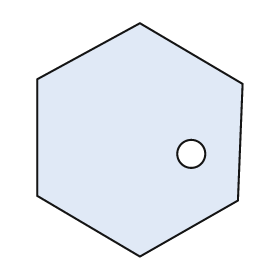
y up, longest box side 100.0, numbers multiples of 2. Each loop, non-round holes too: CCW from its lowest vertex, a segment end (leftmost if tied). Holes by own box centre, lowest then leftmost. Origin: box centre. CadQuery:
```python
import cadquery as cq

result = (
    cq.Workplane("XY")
    .moveTo(0.0, -50.0)
    .lineTo(42.0, -26.0)
    .lineTo(44.0, 24.0)
    .lineTo(0.0, 50.0)
    .lineTo(-44.0, 26.0)
    .lineTo(-44.0, -24.0)
    .close()
    .moveTo(22.0, -6.0)
    .circle(6.0)
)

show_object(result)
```